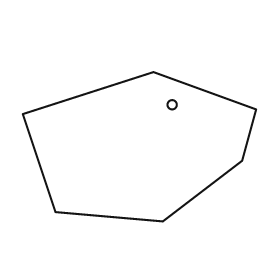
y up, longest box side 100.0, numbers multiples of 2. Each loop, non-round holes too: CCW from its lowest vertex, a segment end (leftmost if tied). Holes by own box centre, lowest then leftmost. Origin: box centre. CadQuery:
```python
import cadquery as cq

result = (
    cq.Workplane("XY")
    .moveTo(10.0, -32.0)
    .lineTo(44.0, -6.0)
    .lineTo(50.0, 16.0)
    .lineTo(6.0, 32.0)
    .lineTo(-50.0, 14.0)
    .lineTo(-36.0, -28.0)
    .close()
    .moveTo(14.0, 18.0)
    .circle(2.0)
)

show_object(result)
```